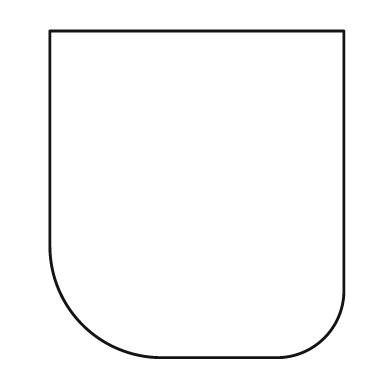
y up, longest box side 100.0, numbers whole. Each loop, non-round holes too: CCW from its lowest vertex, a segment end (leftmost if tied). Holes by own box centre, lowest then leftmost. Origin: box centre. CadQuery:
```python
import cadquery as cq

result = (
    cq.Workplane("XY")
    .moveTo(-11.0, -50.0)
    .lineTo(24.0, -50.0)
    .threePointArc((39.0, -44.0), (45.0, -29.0))
    .lineTo(45.0, 50.0)
    .lineTo(-45.0, 50.0)
    .lineTo(-45.0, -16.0)
    .threePointArc((-35.0, -40.0), (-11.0, -50.0))
    .close()
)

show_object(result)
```